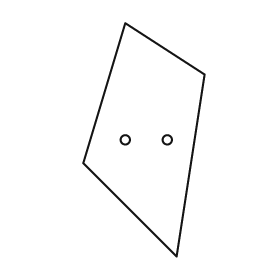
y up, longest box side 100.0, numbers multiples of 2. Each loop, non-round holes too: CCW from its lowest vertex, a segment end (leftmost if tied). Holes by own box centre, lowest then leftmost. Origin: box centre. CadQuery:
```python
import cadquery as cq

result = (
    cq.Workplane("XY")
    .moveTo(14.0, -50.0)
    .lineTo(26.0, 28.0)
    .lineTo(-8.0, 50.0)
    .lineTo(-26.0, -10.0)
    .close()
    .moveTo(-8.0, 0.0)
    .circle(2.0)
    .moveTo(10.0, 0.0)
    .circle(2.0)
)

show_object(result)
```